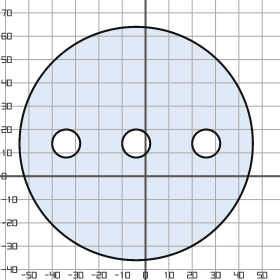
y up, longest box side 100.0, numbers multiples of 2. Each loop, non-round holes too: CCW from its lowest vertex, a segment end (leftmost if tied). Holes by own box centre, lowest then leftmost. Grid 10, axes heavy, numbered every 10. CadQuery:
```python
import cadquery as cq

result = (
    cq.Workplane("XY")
    .moveTo(-4.0, 14.0)
    .circle(50.0)
    .moveTo(-34.0, 14.0)
    .circle(6.0)
    .moveTo(-4.0, 14.0)
    .circle(6.0)
    .moveTo(26.0, 14.0)
    .circle(6.0)
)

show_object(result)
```